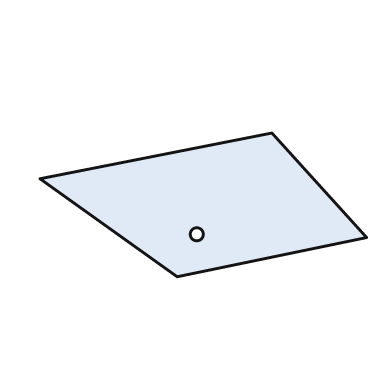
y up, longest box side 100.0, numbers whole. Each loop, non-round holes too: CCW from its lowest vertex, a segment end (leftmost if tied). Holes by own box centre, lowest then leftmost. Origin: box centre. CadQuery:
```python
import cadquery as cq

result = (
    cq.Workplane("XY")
    .moveTo(-8.0, -22.0)
    .lineTo(50.0, -10.0)
    .lineTo(21.0, 22.0)
    .lineTo(-50.0, 8.0)
    .close()
    .moveTo(-2.0, -9.0)
    .circle(2.0)
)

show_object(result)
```